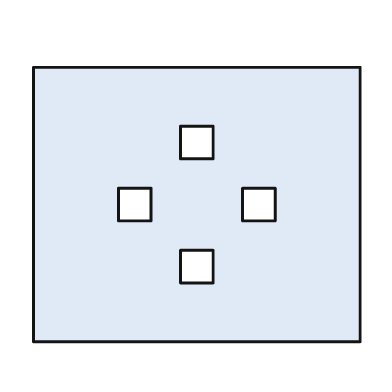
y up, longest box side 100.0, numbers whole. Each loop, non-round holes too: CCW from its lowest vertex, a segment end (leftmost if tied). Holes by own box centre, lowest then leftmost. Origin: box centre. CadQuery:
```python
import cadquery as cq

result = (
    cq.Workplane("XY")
    .moveTo(-50.0, -42.0)
    .lineTo(50.0, -42.0)
    .lineTo(50.0, 42.0)
    .lineTo(-50.0, 42.0)
    .close()
    .moveTo(-5.0, -24.0)
    .lineTo(5.0, -24.0)
    .lineTo(5.0, -14.0)
    .lineTo(-5.0, -14.0)
    .close()
    .moveTo(-24.0, -5.0)
    .lineTo(-14.0, -5.0)
    .lineTo(-14.0, 5.0)
    .lineTo(-24.0, 5.0)
    .close()
    .moveTo(14.0, -5.0)
    .lineTo(24.0, -5.0)
    .lineTo(24.0, 5.0)
    .lineTo(14.0, 5.0)
    .close()
    .moveTo(-5.0, 14.0)
    .lineTo(5.0, 14.0)
    .lineTo(5.0, 24.0)
    .lineTo(-5.0, 24.0)
    .close()
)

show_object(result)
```